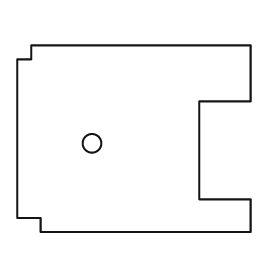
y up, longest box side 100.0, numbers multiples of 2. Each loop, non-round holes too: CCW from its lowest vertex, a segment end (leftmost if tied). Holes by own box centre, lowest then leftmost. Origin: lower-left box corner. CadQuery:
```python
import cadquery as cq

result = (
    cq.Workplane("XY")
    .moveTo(10.0, 0.0)
    .lineTo(100.0, 0.0)
    .lineTo(100.0, 14.0)
    .lineTo(78.0, 14.0)
    .lineTo(78.0, 56.0)
    .lineTo(100.0, 56.0)
    .lineTo(100.0, 80.0)
    .lineTo(6.0, 80.0)
    .lineTo(6.0, 74.0)
    .lineTo(0.0, 74.0)
    .lineTo(0.0, 6.0)
    .lineTo(10.0, 6.0)
    .close()
    .moveTo(32.0, 38.0)
    .circle(4.0)
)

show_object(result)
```